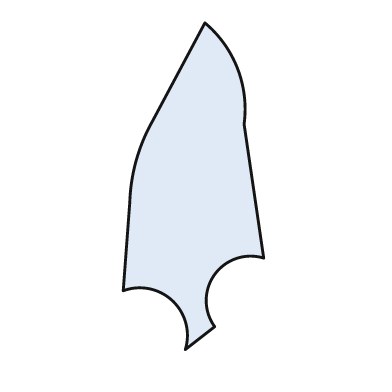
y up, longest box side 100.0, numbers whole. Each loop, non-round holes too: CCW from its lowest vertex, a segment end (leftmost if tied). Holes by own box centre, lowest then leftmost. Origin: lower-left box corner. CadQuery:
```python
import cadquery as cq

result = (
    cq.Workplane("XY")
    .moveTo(19.0, 0.0)
    .lineTo(28.0, 7.0)
    .threePointArc((28.0, 23.0), (43.0, 28.0))
    .lineTo(37.0, 69.0)
    .threePointArc((35.0, 86.0), (25.0, 100.0))
    .lineTo(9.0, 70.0)
    .threePointArc((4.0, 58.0), (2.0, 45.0))
    .lineTo(0.0, 18.0)
    .threePointArc((15.0, 15.0), (19.0, 0.0))
    .close()
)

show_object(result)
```